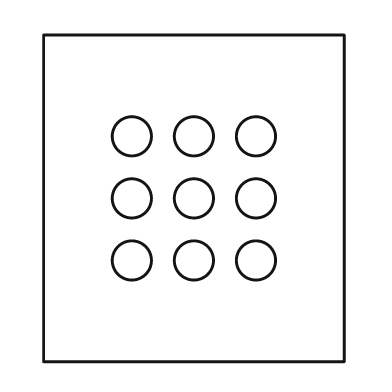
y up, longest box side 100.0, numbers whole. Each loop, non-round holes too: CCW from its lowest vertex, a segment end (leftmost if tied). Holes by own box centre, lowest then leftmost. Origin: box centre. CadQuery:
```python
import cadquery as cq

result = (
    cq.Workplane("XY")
    .moveTo(-46.0, -50.0)
    .lineTo(46.0, -50.0)
    .lineTo(46.0, 50.0)
    .lineTo(-46.0, 50.0)
    .close()
    .moveTo(-19.0, -19.0)
    .circle(6.0)
    .moveTo(0.0, -19.0)
    .circle(6.0)
    .moveTo(19.0, -19.0)
    .circle(6.0)
    .moveTo(-19.0, 0.0)
    .circle(6.0)
    .moveTo(0.0, 0.0)
    .circle(6.0)
    .moveTo(19.0, 0.0)
    .circle(6.0)
    .moveTo(-19.0, 19.0)
    .circle(6.0)
    .moveTo(0.0, 19.0)
    .circle(6.0)
    .moveTo(19.0, 19.0)
    .circle(6.0)
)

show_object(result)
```